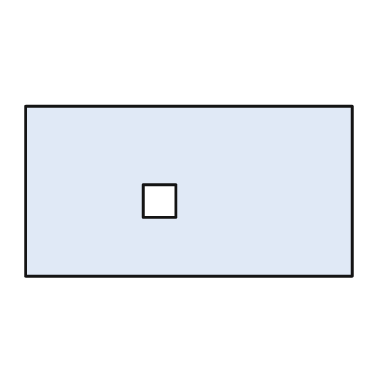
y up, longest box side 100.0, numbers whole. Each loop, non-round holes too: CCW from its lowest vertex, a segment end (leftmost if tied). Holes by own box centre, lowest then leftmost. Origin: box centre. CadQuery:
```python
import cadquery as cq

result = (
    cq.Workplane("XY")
    .moveTo(-50.0, -26.0)
    .lineTo(50.0, -26.0)
    .lineTo(50.0, 26.0)
    .lineTo(-50.0, 26.0)
    .close()
    .moveTo(-14.0, -8.0)
    .lineTo(-4.0, -8.0)
    .lineTo(-4.0, 2.0)
    .lineTo(-14.0, 2.0)
    .close()
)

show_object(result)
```